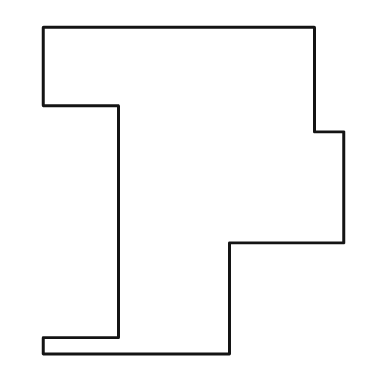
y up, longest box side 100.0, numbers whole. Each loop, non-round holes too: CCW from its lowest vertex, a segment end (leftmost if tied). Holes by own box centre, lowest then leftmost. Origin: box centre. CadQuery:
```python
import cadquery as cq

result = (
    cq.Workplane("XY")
    .moveTo(-46.0, -50.0)
    .lineTo(11.0, -50.0)
    .lineTo(11.0, -16.0)
    .lineTo(46.0, -16.0)
    .lineTo(46.0, 18.0)
    .lineTo(37.0, 18.0)
    .lineTo(37.0, 50.0)
    .lineTo(-46.0, 50.0)
    .lineTo(-46.0, 26.0)
    .lineTo(-23.0, 26.0)
    .lineTo(-23.0, -45.0)
    .lineTo(-46.0, -45.0)
    .close()
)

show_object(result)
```